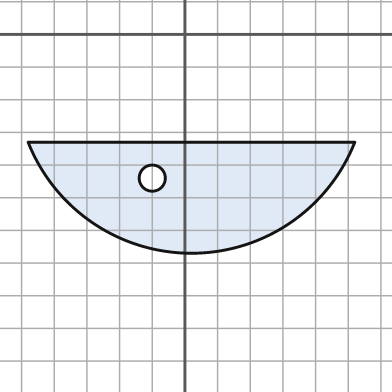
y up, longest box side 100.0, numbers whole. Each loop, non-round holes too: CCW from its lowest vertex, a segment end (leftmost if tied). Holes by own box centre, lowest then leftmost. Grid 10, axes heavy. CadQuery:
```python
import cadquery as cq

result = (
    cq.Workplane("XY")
    .moveTo(-48.0, -33.0)
    .threePointArc((2.0, -67.0), (52.0, -33.0))
    .close()
    .moveTo(-10.0, -44.0)
    .circle(4.0)
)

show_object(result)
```